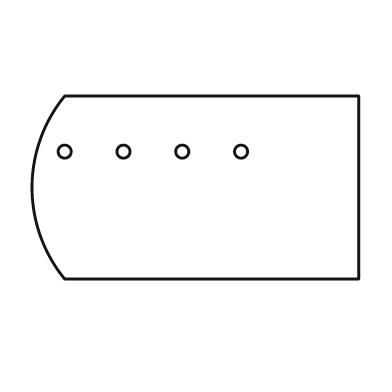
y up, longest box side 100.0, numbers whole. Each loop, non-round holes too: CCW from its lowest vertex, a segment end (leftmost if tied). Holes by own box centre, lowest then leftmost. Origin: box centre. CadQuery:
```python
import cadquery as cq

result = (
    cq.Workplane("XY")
    .moveTo(-40.0, -28.0)
    .lineTo(50.0, -28.0)
    .lineTo(50.0, 28.0)
    .lineTo(-40.0, 28.0)
    .threePointArc((-50.0, 0.0), (-40.0, -28.0))
    .close()
    .moveTo(-40.0, 11.0)
    .circle(2.0)
    .moveTo(-22.0, 11.0)
    .circle(2.0)
    .moveTo(-4.0, 11.0)
    .circle(2.0)
    .moveTo(14.0, 11.0)
    .circle(2.0)
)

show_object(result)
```